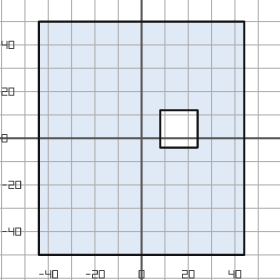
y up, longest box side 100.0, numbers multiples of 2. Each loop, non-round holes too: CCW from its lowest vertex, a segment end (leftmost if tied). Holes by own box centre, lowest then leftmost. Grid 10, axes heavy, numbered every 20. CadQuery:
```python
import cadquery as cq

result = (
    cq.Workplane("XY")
    .moveTo(-44.0, -50.0)
    .lineTo(44.0, -50.0)
    .lineTo(44.0, 50.0)
    .lineTo(-44.0, 50.0)
    .close()
    .moveTo(8.0, -4.0)
    .lineTo(24.0, -4.0)
    .lineTo(24.0, 12.0)
    .lineTo(8.0, 12.0)
    .close()
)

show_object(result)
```